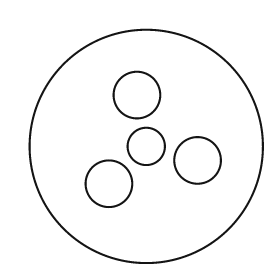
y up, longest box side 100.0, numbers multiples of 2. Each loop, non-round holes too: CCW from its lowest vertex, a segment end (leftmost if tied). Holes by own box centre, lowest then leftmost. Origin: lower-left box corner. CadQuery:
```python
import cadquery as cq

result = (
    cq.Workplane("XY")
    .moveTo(50.0, 50.0)
    .circle(50.0)
    .moveTo(34.0, 34.0)
    .circle(10.0)
    .moveTo(72.0, 44.0)
    .circle(10.0)
    .moveTo(50.0, 50.0)
    .circle(8.0)
    .moveTo(46.0, 72.0)
    .circle(10.0)
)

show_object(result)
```